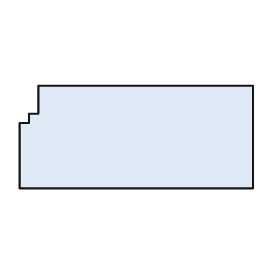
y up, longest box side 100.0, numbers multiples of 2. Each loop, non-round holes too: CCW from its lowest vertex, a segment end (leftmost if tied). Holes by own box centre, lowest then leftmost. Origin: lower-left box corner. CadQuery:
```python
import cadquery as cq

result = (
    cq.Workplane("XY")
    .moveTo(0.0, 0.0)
    .lineTo(100.0, 0.0)
    .lineTo(100.0, 44.0)
    .lineTo(8.0, 44.0)
    .lineTo(8.0, 32.0)
    .lineTo(4.0, 32.0)
    .lineTo(4.0, 28.0)
    .lineTo(0.0, 28.0)
    .close()
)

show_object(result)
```